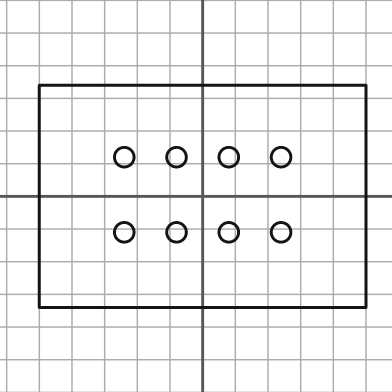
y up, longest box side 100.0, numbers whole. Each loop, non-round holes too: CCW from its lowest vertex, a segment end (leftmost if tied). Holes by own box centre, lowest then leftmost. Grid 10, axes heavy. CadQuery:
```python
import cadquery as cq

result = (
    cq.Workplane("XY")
    .moveTo(-50.0, -34.0)
    .lineTo(50.0, -34.0)
    .lineTo(50.0, 34.0)
    .lineTo(-50.0, 34.0)
    .close()
    .moveTo(-24.0, -11.0)
    .circle(3.0)
    .moveTo(-8.0, -11.0)
    .circle(3.0)
    .moveTo(8.0, -11.0)
    .circle(3.0)
    .moveTo(24.0, -11.0)
    .circle(3.0)
    .moveTo(-24.0, 12.0)
    .circle(3.0)
    .moveTo(-8.0, 12.0)
    .circle(3.0)
    .moveTo(8.0, 12.0)
    .circle(3.0)
    .moveTo(24.0, 12.0)
    .circle(3.0)
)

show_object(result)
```